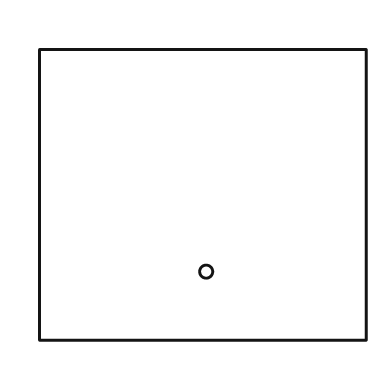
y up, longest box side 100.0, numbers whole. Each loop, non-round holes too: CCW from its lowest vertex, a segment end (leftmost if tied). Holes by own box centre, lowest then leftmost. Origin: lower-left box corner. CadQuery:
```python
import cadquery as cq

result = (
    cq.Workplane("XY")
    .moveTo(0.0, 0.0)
    .lineTo(100.0, 0.0)
    .lineTo(100.0, 89.0)
    .lineTo(0.0, 89.0)
    .close()
    .moveTo(51.0, 21.0)
    .circle(2.0)
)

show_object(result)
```